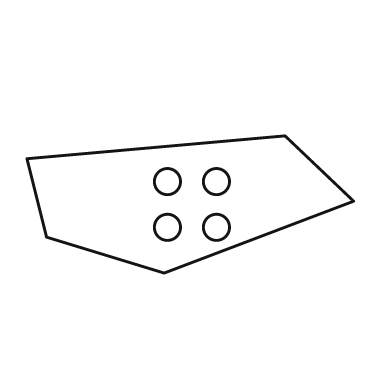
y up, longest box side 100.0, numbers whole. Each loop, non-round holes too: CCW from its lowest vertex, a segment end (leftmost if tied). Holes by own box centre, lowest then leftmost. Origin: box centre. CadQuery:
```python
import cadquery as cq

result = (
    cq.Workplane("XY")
    .moveTo(-8.0, -21.0)
    .lineTo(50.0, 1.0)
    .lineTo(29.0, 21.0)
    .lineTo(-50.0, 14.0)
    .lineTo(-44.0, -10.0)
    .close()
    .moveTo(-7.0, -7.0)
    .circle(4.0)
    .moveTo(8.0, -7.0)
    .circle(4.0)
    .moveTo(-7.0, 7.0)
    .circle(4.0)
    .moveTo(8.0, 7.0)
    .circle(4.0)
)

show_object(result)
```